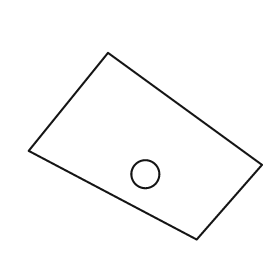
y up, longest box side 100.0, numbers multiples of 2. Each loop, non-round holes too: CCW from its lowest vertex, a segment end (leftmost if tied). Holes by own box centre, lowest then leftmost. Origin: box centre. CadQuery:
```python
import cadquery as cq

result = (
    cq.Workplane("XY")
    .moveTo(22.0, -40.0)
    .lineTo(50.0, -8.0)
    .lineTo(-16.0, 40.0)
    .lineTo(-50.0, -2.0)
    .close()
    .moveTo(0.0, -12.0)
    .circle(6.0)
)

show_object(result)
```